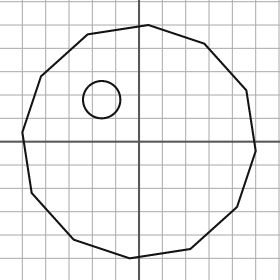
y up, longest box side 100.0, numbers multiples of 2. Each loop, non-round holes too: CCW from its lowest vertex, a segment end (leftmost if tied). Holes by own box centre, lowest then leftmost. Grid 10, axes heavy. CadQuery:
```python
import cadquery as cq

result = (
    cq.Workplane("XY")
    .moveTo(-4.0, -50.0)
    .lineTo(22.0, -46.0)
    .lineTo(42.0, -28.0)
    .lineTo(50.0, -4.0)
    .lineTo(46.0, 22.0)
    .lineTo(28.0, 42.0)
    .lineTo(4.0, 50.0)
    .lineTo(-22.0, 46.0)
    .lineTo(-42.0, 28.0)
    .lineTo(-50.0, 4.0)
    .lineTo(-46.0, -22.0)
    .lineTo(-28.0, -42.0)
    .close()
    .moveTo(-16.0, 18.0)
    .circle(8.0)
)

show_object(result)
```